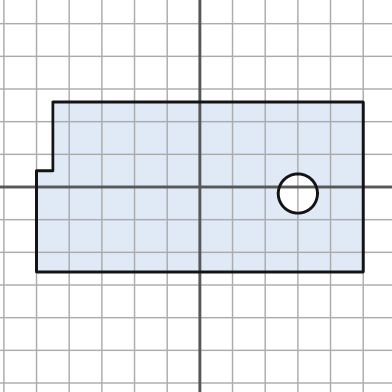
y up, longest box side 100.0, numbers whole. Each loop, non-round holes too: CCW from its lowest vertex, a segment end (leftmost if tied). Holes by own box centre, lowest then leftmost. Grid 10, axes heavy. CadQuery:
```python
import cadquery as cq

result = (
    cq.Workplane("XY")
    .moveTo(-50.0, -26.0)
    .lineTo(50.0, -26.0)
    .lineTo(50.0, 26.0)
    .lineTo(-45.0, 26.0)
    .lineTo(-45.0, 5.0)
    .lineTo(-50.0, 5.0)
    .close()
    .moveTo(30.0, -2.0)
    .circle(6.0)
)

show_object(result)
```